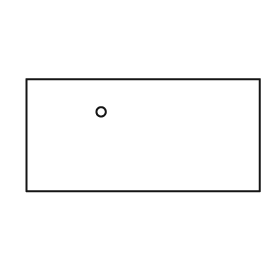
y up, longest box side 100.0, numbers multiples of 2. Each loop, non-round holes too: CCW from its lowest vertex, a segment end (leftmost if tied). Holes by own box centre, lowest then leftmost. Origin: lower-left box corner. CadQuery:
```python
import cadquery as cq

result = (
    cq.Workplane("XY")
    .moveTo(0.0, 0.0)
    .lineTo(100.0, 0.0)
    .lineTo(100.0, 48.0)
    .lineTo(0.0, 48.0)
    .close()
    .moveTo(32.0, 34.0)
    .circle(2.0)
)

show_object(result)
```